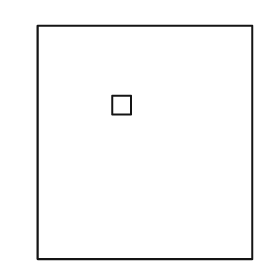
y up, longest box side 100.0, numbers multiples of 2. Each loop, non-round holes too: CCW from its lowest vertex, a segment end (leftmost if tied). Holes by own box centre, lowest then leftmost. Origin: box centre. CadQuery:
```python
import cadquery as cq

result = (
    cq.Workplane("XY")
    .moveTo(-46.0, -50.0)
    .lineTo(46.0, -50.0)
    .lineTo(46.0, 50.0)
    .lineTo(-46.0, 50.0)
    .close()
    .moveTo(-14.0, 12.0)
    .lineTo(-6.0, 12.0)
    .lineTo(-6.0, 20.0)
    .lineTo(-14.0, 20.0)
    .close()
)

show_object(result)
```